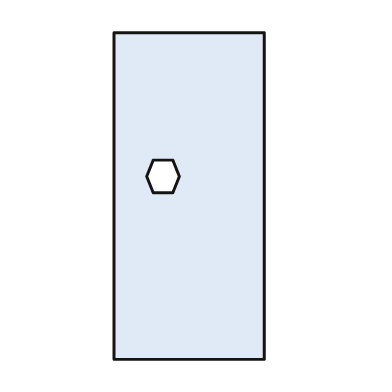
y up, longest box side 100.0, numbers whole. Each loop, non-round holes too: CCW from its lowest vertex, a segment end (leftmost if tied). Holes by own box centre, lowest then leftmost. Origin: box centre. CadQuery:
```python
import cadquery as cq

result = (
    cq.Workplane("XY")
    .moveTo(-23.0, -50.0)
    .lineTo(23.0, -50.0)
    .lineTo(23.0, 50.0)
    .lineTo(-23.0, 50.0)
    .close()
    .moveTo(-11.0, 1.0)
    .lineTo(-5.0, 1.0)
    .lineTo(-3.0, 6.0)
    .lineTo(-5.0, 11.0)
    .lineTo(-11.0, 11.0)
    .lineTo(-13.0, 6.0)
    .close()
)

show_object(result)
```